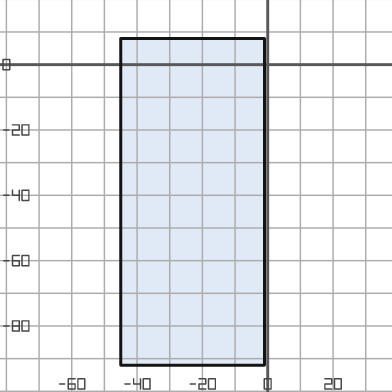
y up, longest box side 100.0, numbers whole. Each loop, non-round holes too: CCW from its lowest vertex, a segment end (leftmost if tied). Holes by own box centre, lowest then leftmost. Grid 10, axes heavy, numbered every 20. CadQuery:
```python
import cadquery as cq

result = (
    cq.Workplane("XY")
    .moveTo(-45.0, -92.0)
    .lineTo(-1.0, -92.0)
    .lineTo(-1.0, 8.0)
    .lineTo(-45.0, 8.0)
    .close()
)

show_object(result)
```